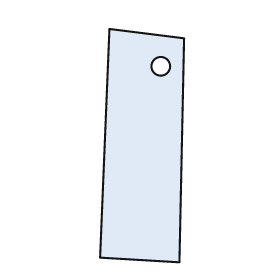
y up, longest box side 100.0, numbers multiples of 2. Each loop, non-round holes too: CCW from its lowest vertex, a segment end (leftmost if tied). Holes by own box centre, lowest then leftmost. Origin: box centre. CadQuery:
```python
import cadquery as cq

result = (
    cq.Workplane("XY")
    .moveTo(16.0, -50.0)
    .lineTo(18.0, 46.0)
    .lineTo(-14.0, 50.0)
    .lineTo(-18.0, -48.0)
    .close()
    .moveTo(8.0, 34.0)
    .circle(4.0)
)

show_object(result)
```